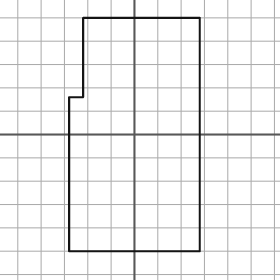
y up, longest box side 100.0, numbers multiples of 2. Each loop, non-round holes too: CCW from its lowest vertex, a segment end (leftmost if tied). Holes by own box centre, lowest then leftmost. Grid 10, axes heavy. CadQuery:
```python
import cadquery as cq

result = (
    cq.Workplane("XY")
    .moveTo(-28.0, -50.0)
    .lineTo(28.0, -50.0)
    .lineTo(28.0, 50.0)
    .lineTo(-22.0, 50.0)
    .lineTo(-22.0, 16.0)
    .lineTo(-28.0, 16.0)
    .close()
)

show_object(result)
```